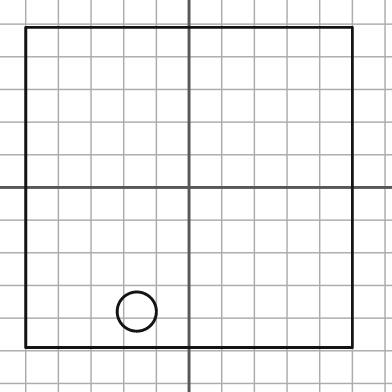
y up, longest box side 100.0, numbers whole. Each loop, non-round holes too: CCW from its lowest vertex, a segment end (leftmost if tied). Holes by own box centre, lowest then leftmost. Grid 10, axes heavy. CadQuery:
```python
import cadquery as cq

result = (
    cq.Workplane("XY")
    .moveTo(-50.0, -49.0)
    .lineTo(50.0, -49.0)
    .lineTo(50.0, 49.0)
    .lineTo(-50.0, 49.0)
    .close()
    .moveTo(-16.0, -38.0)
    .circle(6.0)
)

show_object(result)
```